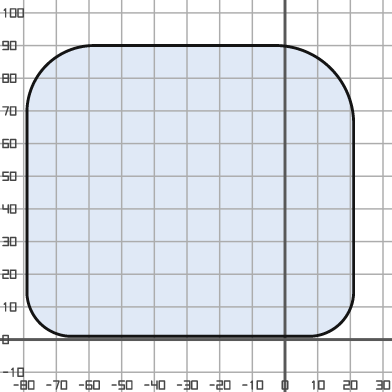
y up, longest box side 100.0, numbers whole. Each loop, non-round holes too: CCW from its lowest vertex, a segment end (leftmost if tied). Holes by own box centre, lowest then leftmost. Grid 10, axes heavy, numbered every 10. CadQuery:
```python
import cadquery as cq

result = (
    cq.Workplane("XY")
    .moveTo(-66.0, 1.0)
    .lineTo(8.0, 1.0)
    .threePointArc((17.0, 5.0), (21.0, 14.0))
    .lineTo(21.0, 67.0)
    .threePointArc((14.0, 83.0), (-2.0, 90.0))
    .lineTo(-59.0, 90.0)
    .threePointArc((-73.0, 84.0), (-79.0, 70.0))
    .lineTo(-79.0, 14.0)
    .threePointArc((-75.0, 5.0), (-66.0, 1.0))
    .close()
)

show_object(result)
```